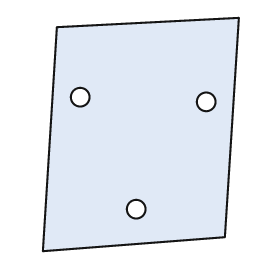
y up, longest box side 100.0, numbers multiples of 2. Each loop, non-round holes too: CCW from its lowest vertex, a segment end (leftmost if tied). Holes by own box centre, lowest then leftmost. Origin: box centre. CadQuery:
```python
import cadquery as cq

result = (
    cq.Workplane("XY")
    .moveTo(-42.0, -50.0)
    .lineTo(36.0, -44.0)
    .lineTo(42.0, 50.0)
    .lineTo(-36.0, 46.0)
    .close()
    .moveTo(-2.0, -32.0)
    .circle(4.0)
    .moveTo(28.0, 14.0)
    .circle(4.0)
    .moveTo(-26.0, 16.0)
    .circle(4.0)
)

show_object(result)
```